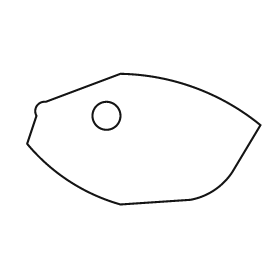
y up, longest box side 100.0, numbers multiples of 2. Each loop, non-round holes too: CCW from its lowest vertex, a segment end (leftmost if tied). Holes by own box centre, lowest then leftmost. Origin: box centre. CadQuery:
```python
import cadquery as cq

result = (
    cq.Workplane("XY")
    .moveTo(-10.0, -28.0)
    .lineTo(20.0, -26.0)
    .threePointArc((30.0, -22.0), (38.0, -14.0))
    .lineTo(50.0, 6.0)
    .threePointArc((22.0, 22.0), (-10.0, 28.0))
    .lineTo(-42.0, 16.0)
    .threePointArc((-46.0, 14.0), (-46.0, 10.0))
    .lineTo(-50.0, -2.0)
    .threePointArc((-32.0, -18.0), (-10.0, -28.0))
    .close()
    .moveTo(-16.0, 10.0)
    .circle(6.0)
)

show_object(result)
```